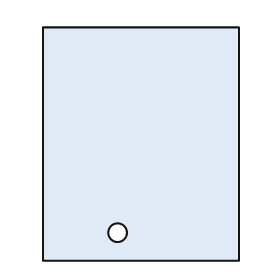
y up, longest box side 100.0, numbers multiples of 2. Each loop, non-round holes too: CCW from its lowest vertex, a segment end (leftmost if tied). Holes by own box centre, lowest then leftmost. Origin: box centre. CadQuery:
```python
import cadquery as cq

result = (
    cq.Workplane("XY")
    .moveTo(-42.0, -50.0)
    .lineTo(42.0, -50.0)
    .lineTo(42.0, 50.0)
    .lineTo(-42.0, 50.0)
    .close()
    .moveTo(-10.0, -38.0)
    .circle(4.0)
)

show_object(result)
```